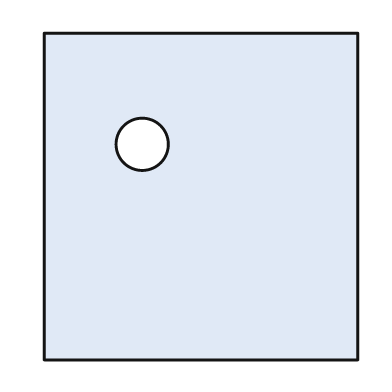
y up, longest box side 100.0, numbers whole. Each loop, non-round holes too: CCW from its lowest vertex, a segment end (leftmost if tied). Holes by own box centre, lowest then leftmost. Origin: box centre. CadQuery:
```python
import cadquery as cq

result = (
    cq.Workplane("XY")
    .moveTo(-48.0, -50.0)
    .lineTo(48.0, -50.0)
    .lineTo(48.0, 50.0)
    .lineTo(-48.0, 50.0)
    .close()
    .moveTo(-18.0, 16.0)
    .circle(8.0)
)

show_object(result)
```